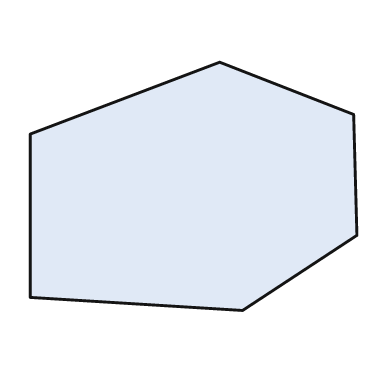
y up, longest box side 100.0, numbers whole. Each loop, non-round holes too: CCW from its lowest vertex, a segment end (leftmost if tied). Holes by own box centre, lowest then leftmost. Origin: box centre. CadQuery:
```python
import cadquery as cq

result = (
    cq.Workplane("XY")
    .moveTo(15.0, -38.0)
    .lineTo(50.0, -15.0)
    .lineTo(49.0, 22.0)
    .lineTo(8.0, 38.0)
    .lineTo(-50.0, 16.0)
    .lineTo(-50.0, -34.0)
    .close()
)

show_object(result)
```